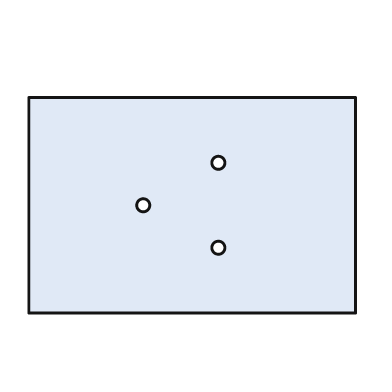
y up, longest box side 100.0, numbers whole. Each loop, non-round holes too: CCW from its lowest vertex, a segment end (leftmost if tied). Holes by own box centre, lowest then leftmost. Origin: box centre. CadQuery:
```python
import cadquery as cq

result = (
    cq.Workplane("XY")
    .moveTo(-50.0, -33.0)
    .lineTo(50.0, -33.0)
    .lineTo(50.0, 33.0)
    .lineTo(-50.0, 33.0)
    .close()
    .moveTo(8.0, -13.0)
    .circle(2.0)
    .moveTo(-15.0, 0.0)
    .circle(2.0)
    .moveTo(8.0, 13.0)
    .circle(2.0)
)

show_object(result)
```